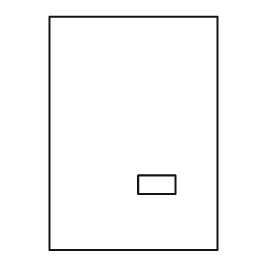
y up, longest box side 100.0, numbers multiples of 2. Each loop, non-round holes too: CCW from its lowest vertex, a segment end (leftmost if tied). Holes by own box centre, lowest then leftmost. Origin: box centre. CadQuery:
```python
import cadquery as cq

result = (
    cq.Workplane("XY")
    .moveTo(-36.0, -50.0)
    .lineTo(36.0, -50.0)
    .lineTo(36.0, 50.0)
    .lineTo(-36.0, 50.0)
    .close()
    .moveTo(2.0, -26.0)
    .lineTo(18.0, -26.0)
    .lineTo(18.0, -18.0)
    .lineTo(2.0, -18.0)
    .close()
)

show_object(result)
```